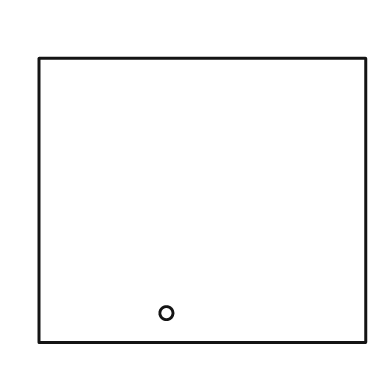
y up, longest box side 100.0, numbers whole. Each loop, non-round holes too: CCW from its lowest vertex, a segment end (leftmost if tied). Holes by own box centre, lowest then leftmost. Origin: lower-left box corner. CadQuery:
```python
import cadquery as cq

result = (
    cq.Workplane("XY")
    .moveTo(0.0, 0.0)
    .lineTo(100.0, 0.0)
    .lineTo(100.0, 87.0)
    .lineTo(0.0, 87.0)
    .close()
    .moveTo(39.0, 9.0)
    .circle(2.0)
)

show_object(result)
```